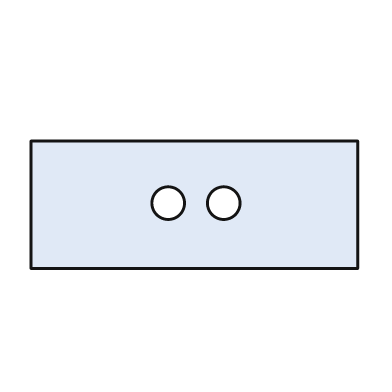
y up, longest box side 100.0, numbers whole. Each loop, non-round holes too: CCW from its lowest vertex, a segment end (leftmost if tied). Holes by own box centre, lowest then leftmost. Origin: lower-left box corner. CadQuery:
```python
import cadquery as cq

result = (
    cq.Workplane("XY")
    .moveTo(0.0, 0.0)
    .lineTo(100.0, 0.0)
    .lineTo(100.0, 39.0)
    .lineTo(0.0, 39.0)
    .close()
    .moveTo(42.0, 20.0)
    .circle(5.0)
    .moveTo(59.0, 20.0)
    .circle(5.0)
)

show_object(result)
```